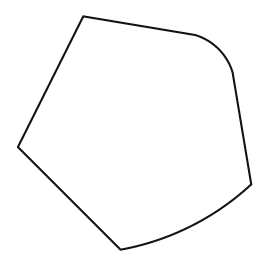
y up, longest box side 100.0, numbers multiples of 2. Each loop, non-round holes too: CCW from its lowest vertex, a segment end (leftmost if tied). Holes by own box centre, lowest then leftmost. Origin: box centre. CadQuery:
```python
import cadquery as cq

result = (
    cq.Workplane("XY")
    .moveTo(-6.0, -50.0)
    .threePointArc((24.0, -40.0), (50.0, -22.0))
    .lineTo(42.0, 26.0)
    .threePointArc((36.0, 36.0), (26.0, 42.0))
    .lineTo(-22.0, 50.0)
    .lineTo(-50.0, -6.0)
    .close()
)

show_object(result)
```